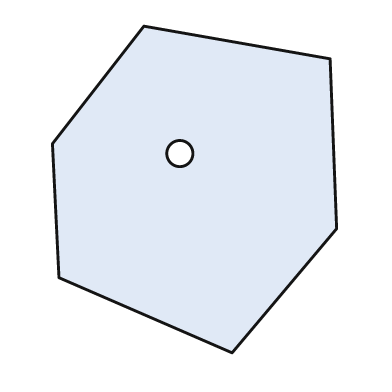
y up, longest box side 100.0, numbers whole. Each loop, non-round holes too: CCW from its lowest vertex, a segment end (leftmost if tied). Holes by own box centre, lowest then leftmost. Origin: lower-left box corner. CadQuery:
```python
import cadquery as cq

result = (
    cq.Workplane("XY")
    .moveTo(55.0, 0.0)
    .lineTo(87.0, 38.0)
    .lineTo(85.0, 90.0)
    .lineTo(28.0, 100.0)
    .lineTo(0.0, 64.0)
    .lineTo(2.0, 23.0)
    .close()
    .moveTo(39.0, 61.0)
    .circle(4.0)
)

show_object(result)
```